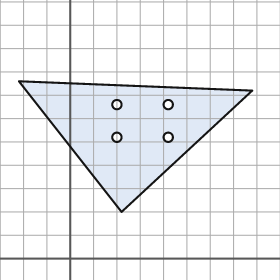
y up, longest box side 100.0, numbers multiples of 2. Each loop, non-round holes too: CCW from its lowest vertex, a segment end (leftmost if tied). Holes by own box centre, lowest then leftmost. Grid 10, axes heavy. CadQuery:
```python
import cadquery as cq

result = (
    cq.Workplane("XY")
    .moveTo(22.0, 20.0)
    .lineTo(78.0, 72.0)
    .lineTo(-22.0, 76.0)
    .close()
    .moveTo(20.0, 52.0)
    .circle(2.0)
    .moveTo(42.0, 52.0)
    .circle(2.0)
    .moveTo(20.0, 66.0)
    .circle(2.0)
    .moveTo(42.0, 66.0)
    .circle(2.0)
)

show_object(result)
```